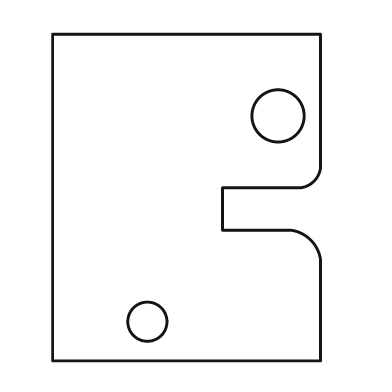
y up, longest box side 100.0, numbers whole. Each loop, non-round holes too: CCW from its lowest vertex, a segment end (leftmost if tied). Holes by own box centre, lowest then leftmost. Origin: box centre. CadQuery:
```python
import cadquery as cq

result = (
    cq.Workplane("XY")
    .moveTo(-41.0, -50.0)
    .lineTo(41.0, -50.0)
    .lineTo(41.0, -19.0)
    .threePointArc((38.0, -13.0), (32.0, -10.0))
    .lineTo(11.0, -10.0)
    .lineTo(11.0, 3.0)
    .lineTo(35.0, 3.0)
    .threePointArc((39.0, 5.0), (41.0, 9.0))
    .lineTo(41.0, 50.0)
    .lineTo(-41.0, 50.0)
    .close()
    .moveTo(-12.0, -38.0)
    .circle(6.0)
    .moveTo(28.0, 25.0)
    .circle(8.0)
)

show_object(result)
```